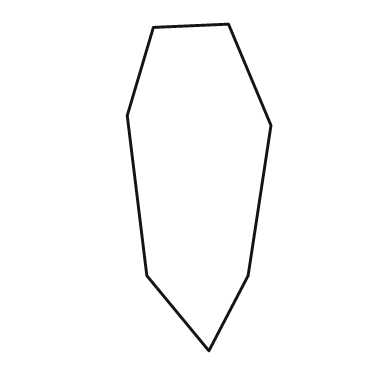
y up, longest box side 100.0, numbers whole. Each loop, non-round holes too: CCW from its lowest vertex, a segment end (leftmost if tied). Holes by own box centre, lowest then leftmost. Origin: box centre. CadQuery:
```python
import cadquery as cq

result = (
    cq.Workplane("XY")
    .moveTo(3.0, -50.0)
    .lineTo(15.0, -27.0)
    .lineTo(22.0, 19.0)
    .lineTo(9.0, 50.0)
    .lineTo(-14.0, 49.0)
    .lineTo(-22.0, 22.0)
    .lineTo(-16.0, -27.0)
    .close()
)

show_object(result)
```